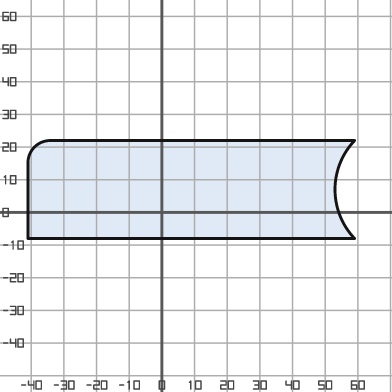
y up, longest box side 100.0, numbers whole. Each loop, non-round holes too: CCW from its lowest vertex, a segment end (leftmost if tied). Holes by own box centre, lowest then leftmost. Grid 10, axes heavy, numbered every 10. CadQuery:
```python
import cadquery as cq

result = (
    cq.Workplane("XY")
    .moveTo(-41.0, -8.0)
    .lineTo(59.0, -8.0)
    .threePointArc((53.0, 7.0), (59.0, 22.0))
    .lineTo(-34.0, 22.0)
    .threePointArc((-39.0, 20.0), (-41.0, 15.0))
    .close()
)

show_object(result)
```